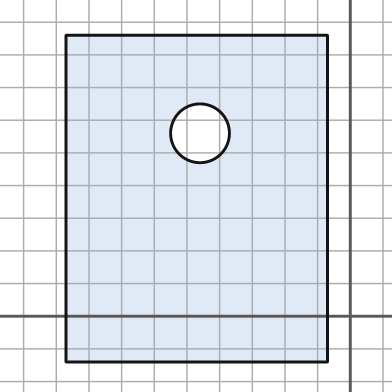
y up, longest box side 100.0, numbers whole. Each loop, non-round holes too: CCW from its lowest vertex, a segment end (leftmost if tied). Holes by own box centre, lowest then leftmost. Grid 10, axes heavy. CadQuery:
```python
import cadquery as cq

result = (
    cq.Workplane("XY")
    .moveTo(-87.0, -14.0)
    .lineTo(-7.0, -14.0)
    .lineTo(-7.0, 86.0)
    .lineTo(-87.0, 86.0)
    .close()
    .moveTo(-46.0, 56.0)
    .circle(9.0)
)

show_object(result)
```